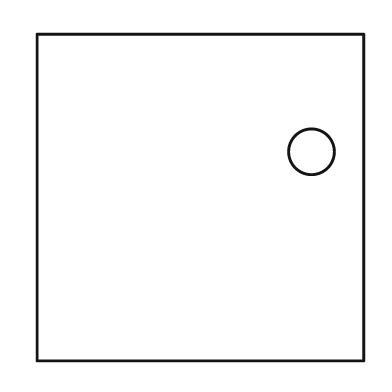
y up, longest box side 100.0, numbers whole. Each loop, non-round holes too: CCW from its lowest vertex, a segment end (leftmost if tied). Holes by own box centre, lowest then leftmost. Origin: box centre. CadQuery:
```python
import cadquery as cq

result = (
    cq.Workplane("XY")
    .moveTo(-50.0, -50.0)
    .lineTo(50.0, -50.0)
    .lineTo(50.0, 50.0)
    .lineTo(-50.0, 50.0)
    .close()
    .moveTo(34.0, 14.0)
    .circle(7.0)
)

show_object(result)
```